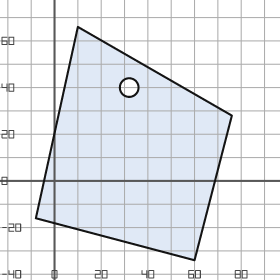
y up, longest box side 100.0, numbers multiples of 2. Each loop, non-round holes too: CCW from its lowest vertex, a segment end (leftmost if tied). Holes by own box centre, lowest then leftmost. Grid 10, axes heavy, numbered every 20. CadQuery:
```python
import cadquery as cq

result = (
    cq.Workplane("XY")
    .moveTo(60.0, -34.0)
    .lineTo(76.0, 28.0)
    .lineTo(10.0, 66.0)
    .lineTo(-8.0, -16.0)
    .close()
    .moveTo(32.0, 40.0)
    .circle(4.0)
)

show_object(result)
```